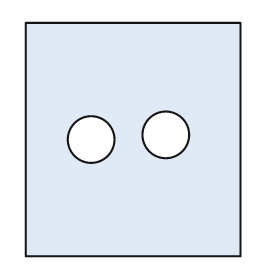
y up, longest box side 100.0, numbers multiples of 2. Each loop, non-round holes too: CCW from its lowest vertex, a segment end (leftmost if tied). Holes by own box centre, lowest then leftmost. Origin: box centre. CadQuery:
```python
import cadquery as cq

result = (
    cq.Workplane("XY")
    .moveTo(-46.0, -50.0)
    .lineTo(46.0, -50.0)
    .lineTo(46.0, 50.0)
    .lineTo(-46.0, 50.0)
    .close()
    .moveTo(-18.0, 0.0)
    .circle(10.0)
    .moveTo(14.0, 2.0)
    .circle(10.0)
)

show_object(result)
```